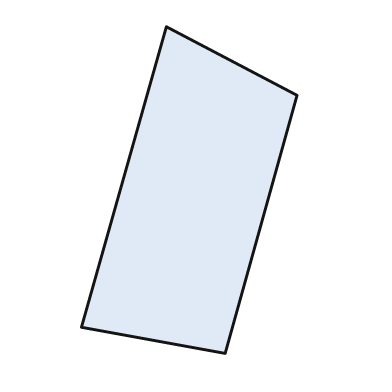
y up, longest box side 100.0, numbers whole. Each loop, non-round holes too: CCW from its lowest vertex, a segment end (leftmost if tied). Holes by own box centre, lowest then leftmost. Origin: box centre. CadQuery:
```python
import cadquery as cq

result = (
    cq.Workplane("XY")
    .moveTo(11.0, -50.0)
    .lineTo(33.0, 29.0)
    .lineTo(-7.0, 50.0)
    .lineTo(-33.0, -42.0)
    .close()
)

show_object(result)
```